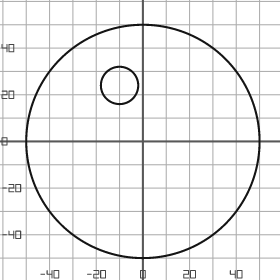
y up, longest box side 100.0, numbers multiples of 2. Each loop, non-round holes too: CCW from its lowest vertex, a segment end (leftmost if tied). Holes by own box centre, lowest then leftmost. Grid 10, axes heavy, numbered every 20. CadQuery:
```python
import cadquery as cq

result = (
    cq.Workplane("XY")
    .moveTo(0.0, 0.0)
    .circle(50.0)
    .moveTo(-10.0, 24.0)
    .circle(8.0)
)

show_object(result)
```